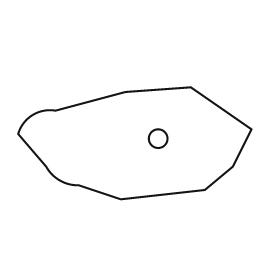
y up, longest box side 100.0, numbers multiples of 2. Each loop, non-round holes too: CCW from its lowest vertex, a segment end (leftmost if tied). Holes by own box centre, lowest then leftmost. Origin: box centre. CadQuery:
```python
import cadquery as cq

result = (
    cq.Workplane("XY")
    .moveTo(-6.0, -24.0)
    .lineTo(30.0, -20.0)
    .lineTo(42.0, -10.0)
    .lineTo(50.0, 6.0)
    .lineTo(24.0, 24.0)
    .lineTo(-4.0, 22.0)
    .lineTo(-34.0, 14.0)
    .threePointArc((-44.0, 12.0), (-50.0, 4.0))
    .lineTo(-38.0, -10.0)
    .threePointArc((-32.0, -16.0), (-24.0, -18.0))
    .close()
    .moveTo(10.0, 2.0)
    .circle(4.0)
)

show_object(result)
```